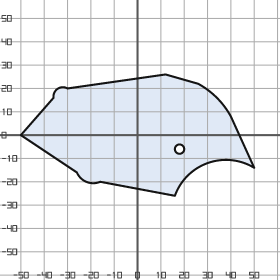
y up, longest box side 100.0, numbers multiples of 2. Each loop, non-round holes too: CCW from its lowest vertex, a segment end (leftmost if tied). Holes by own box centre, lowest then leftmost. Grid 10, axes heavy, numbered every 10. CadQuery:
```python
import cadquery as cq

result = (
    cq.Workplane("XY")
    .moveTo(16.0, -26.0)
    .threePointArc((30.0, -12.0), (50.0, -14.0))
    .lineTo(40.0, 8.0)
    .threePointArc((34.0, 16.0), (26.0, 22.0))
    .lineTo(12.0, 26.0)
    .lineTo(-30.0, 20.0)
    .threePointArc((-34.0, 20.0), (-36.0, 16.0))
    .lineTo(-50.0, 0.0)
    .lineTo(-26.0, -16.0)
    .threePointArc((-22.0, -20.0), (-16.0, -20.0))
    .close()
    .moveTo(18.0, -6.0)
    .circle(2.0)
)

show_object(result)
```